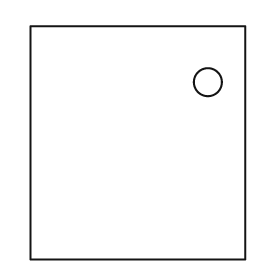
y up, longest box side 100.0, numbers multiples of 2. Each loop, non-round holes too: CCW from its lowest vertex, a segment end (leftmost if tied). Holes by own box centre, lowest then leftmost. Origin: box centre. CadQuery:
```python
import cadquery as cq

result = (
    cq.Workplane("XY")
    .moveTo(-46.0, -50.0)
    .lineTo(46.0, -50.0)
    .lineTo(46.0, 50.0)
    .lineTo(-46.0, 50.0)
    .close()
    .moveTo(30.0, 26.0)
    .circle(6.0)
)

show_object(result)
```